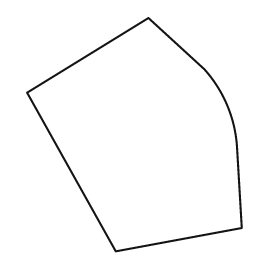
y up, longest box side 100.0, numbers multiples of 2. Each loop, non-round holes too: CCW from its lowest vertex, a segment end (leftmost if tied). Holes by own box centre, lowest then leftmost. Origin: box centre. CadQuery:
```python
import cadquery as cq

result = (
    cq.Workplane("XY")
    .moveTo(-8.0, -50.0)
    .lineTo(46.0, -40.0)
    .lineTo(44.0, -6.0)
    .threePointArc((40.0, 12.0), (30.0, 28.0))
    .lineTo(6.0, 50.0)
    .lineTo(-46.0, 18.0)
    .close()
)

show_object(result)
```